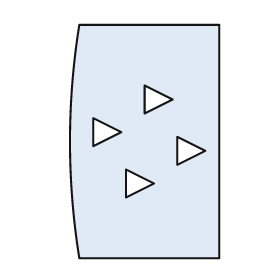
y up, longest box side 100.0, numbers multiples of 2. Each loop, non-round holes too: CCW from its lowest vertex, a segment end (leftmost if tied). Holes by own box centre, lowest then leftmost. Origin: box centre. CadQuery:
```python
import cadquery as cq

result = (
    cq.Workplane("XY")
    .moveTo(-28.0, -50.0)
    .lineTo(32.0, -50.0)
    .lineTo(32.0, 50.0)
    .lineTo(-28.0, 50.0)
    .threePointArc((-32.0, 0.0), (-28.0, -50.0))
    .close()
    .moveTo(-8.0, -24.0)
    .lineTo(4.0, -18.0)
    .lineTo(-8.0, -12.0)
    .close()
    .moveTo(14.0, -10.0)
    .lineTo(26.0, -4.0)
    .lineTo(14.0, 2.0)
    .close()
    .moveTo(-22.0, -2.0)
    .lineTo(-10.0, 4.0)
    .lineTo(-22.0, 10.0)
    .close()
    .moveTo(0.0, 12.0)
    .lineTo(12.0, 18.0)
    .lineTo(0.0, 24.0)
    .close()
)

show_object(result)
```